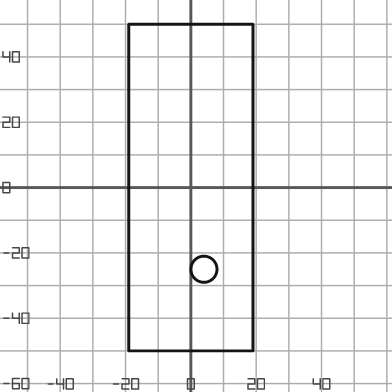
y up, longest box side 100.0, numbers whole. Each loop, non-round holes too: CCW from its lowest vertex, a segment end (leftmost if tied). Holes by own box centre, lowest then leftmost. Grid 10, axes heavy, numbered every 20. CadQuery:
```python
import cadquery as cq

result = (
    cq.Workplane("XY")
    .moveTo(-19.0, -50.0)
    .lineTo(19.0, -50.0)
    .lineTo(19.0, 50.0)
    .lineTo(-19.0, 50.0)
    .close()
    .moveTo(4.0, -25.0)
    .circle(4.0)
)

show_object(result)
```